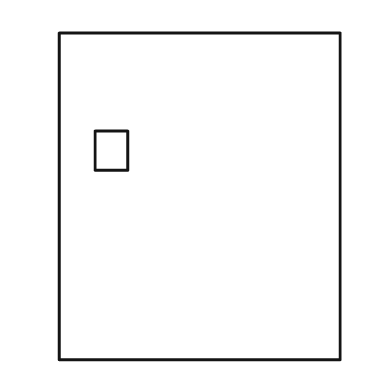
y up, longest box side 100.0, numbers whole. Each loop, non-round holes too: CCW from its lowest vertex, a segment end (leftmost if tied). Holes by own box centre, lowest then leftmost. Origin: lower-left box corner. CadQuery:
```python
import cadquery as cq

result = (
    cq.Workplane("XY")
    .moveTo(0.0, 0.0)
    .lineTo(86.0, 0.0)
    .lineTo(86.0, 100.0)
    .lineTo(0.0, 100.0)
    .close()
    .moveTo(11.0, 58.0)
    .lineTo(21.0, 58.0)
    .lineTo(21.0, 70.0)
    .lineTo(11.0, 70.0)
    .close()
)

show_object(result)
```